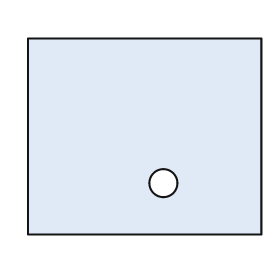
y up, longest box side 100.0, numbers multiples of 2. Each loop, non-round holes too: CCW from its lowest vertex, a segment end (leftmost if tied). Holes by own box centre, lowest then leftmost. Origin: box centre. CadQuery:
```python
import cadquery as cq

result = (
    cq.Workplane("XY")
    .moveTo(-50.0, -42.0)
    .lineTo(50.0, -42.0)
    .lineTo(50.0, 42.0)
    .lineTo(-50.0, 42.0)
    .close()
    .moveTo(8.0, -20.0)
    .circle(6.0)
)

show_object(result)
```